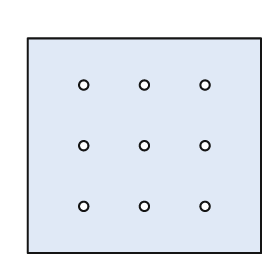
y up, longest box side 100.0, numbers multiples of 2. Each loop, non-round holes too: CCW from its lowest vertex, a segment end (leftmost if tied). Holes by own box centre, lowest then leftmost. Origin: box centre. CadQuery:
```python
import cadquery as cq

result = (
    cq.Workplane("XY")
    .moveTo(-50.0, -46.0)
    .lineTo(50.0, -46.0)
    .lineTo(50.0, 46.0)
    .lineTo(-50.0, 46.0)
    .close()
    .moveTo(-26.0, -26.0)
    .circle(2.0)
    .moveTo(0.0, -26.0)
    .circle(2.0)
    .moveTo(26.0, -26.0)
    .circle(2.0)
    .moveTo(-26.0, 0.0)
    .circle(2.0)
    .moveTo(0.0, 0.0)
    .circle(2.0)
    .moveTo(26.0, 0.0)
    .circle(2.0)
    .moveTo(-26.0, 26.0)
    .circle(2.0)
    .moveTo(0.0, 26.0)
    .circle(2.0)
    .moveTo(26.0, 26.0)
    .circle(2.0)
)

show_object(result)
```